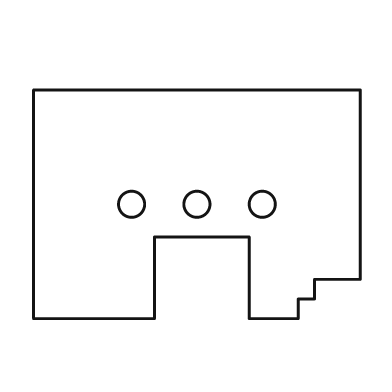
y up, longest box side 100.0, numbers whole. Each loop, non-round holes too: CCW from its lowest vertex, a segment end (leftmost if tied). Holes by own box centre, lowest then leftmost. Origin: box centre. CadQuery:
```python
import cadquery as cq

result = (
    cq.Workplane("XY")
    .moveTo(-50.0, -35.0)
    .lineTo(-13.0, -35.0)
    .lineTo(-13.0, -10.0)
    .lineTo(16.0, -10.0)
    .lineTo(16.0, -35.0)
    .lineTo(31.0, -35.0)
    .lineTo(31.0, -29.0)
    .lineTo(36.0, -29.0)
    .lineTo(36.0, -23.0)
    .lineTo(50.0, -23.0)
    .lineTo(50.0, 35.0)
    .lineTo(-50.0, 35.0)
    .close()
    .moveTo(-20.0, 0.0)
    .circle(4.0)
    .moveTo(0.0, 0.0)
    .circle(4.0)
    .moveTo(20.0, 0.0)
    .circle(4.0)
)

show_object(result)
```